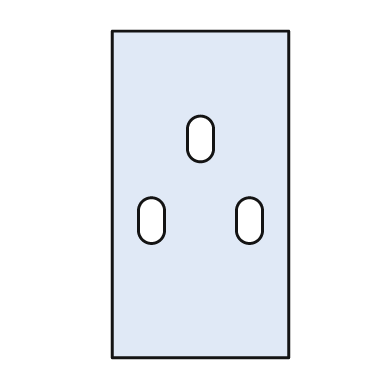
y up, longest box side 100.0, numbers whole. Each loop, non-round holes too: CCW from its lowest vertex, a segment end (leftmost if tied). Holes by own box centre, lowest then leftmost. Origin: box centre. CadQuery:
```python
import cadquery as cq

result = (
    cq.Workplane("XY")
    .moveTo(-27.0, -50.0)
    .lineTo(27.0, -50.0)
    .lineTo(27.0, 50.0)
    .lineTo(-27.0, 50.0)
    .close()
    .moveTo(-19.0, -11.0)
    .threePointArc((-15.0, -15.0), (-11.0, -11.0))
    .lineTo(-11.0, -5.0)
    .threePointArc((-15.0, -1.0), (-19.0, -5.0))
    .close()
    .moveTo(11.0, -11.0)
    .threePointArc((15.0, -15.0), (19.0, -11.0))
    .lineTo(19.0, -5.0)
    .threePointArc((15.0, -1.0), (11.0, -5.0))
    .close()
    .moveTo(-4.0, 14.0)
    .threePointArc((0.0, 10.0), (4.0, 14.0))
    .lineTo(4.0, 20.0)
    .threePointArc((0.0, 24.0), (-4.0, 20.0))
    .close()
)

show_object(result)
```